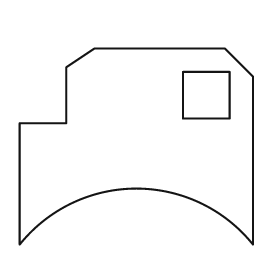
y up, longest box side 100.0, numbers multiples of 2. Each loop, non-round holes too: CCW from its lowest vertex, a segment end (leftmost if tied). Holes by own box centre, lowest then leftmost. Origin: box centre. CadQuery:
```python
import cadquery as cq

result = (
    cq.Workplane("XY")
    .moveTo(-50.0, -42.0)
    .threePointArc((0.0, -18.0), (50.0, -42.0))
    .lineTo(50.0, 30.0)
    .lineTo(38.0, 42.0)
    .lineTo(-18.0, 42.0)
    .lineTo(-30.0, 34.0)
    .lineTo(-30.0, 10.0)
    .lineTo(-50.0, 10.0)
    .close()
    .moveTo(20.0, 12.0)
    .lineTo(40.0, 12.0)
    .lineTo(40.0, 32.0)
    .lineTo(20.0, 32.0)
    .close()
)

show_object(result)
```